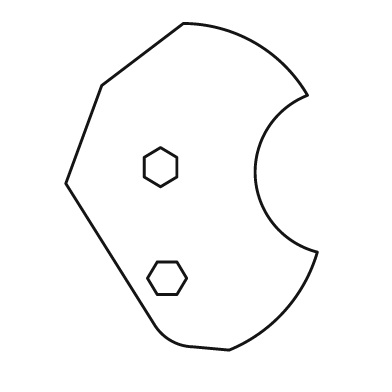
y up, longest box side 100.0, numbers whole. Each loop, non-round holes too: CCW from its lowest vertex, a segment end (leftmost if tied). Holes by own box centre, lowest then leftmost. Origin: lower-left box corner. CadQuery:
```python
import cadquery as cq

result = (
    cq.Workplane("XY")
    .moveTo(50.0, 0.0)
    .threePointArc((67.0, 12.0), (77.0, 30.0))
    .threePointArc((58.0, 53.0), (74.0, 78.0))
    .threePointArc((58.0, 94.0), (36.0, 100.0))
    .lineTo(11.0, 81.0)
    .lineTo(0.0, 51.0)
    .lineTo(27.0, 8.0)
    .threePointArc((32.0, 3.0), (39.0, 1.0))
    .close()
    .moveTo(28.0, 17.0)
    .lineTo(34.0, 17.0)
    .lineTo(37.0, 22.0)
    .lineTo(34.0, 27.0)
    .lineTo(28.0, 27.0)
    .lineTo(25.0, 22.0)
    .close()
    .moveTo(29.0, 50.0)
    .lineTo(34.0, 53.0)
    .lineTo(34.0, 59.0)
    .lineTo(29.0, 62.0)
    .lineTo(24.0, 59.0)
    .lineTo(24.0, 53.0)
    .close()
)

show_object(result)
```